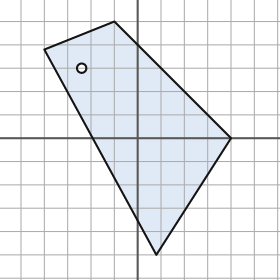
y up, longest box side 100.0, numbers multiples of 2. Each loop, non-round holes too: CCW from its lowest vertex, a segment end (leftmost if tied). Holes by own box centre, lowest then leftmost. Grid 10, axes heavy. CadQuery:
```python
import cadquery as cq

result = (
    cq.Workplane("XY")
    .moveTo(8.0, -50.0)
    .lineTo(40.0, 0.0)
    .lineTo(-10.0, 50.0)
    .lineTo(-40.0, 38.0)
    .close()
    .moveTo(-24.0, 30.0)
    .circle(2.0)
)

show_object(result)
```